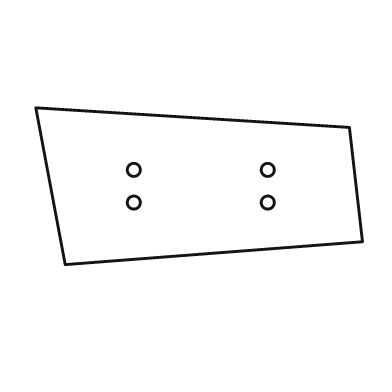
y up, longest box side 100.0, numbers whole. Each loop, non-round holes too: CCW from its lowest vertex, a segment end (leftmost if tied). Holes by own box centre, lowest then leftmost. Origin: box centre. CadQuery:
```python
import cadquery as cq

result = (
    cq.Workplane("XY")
    .moveTo(-41.0, -24.0)
    .lineTo(50.0, -17.0)
    .lineTo(46.0, 18.0)
    .lineTo(-50.0, 24.0)
    .close()
    .moveTo(-20.0, -5.0)
    .circle(2.0)
    .moveTo(21.0, -5.0)
    .circle(2.0)
    .moveTo(-20.0, 5.0)
    .circle(2.0)
    .moveTo(21.0, 5.0)
    .circle(2.0)
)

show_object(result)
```